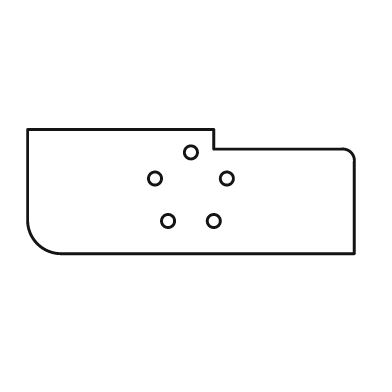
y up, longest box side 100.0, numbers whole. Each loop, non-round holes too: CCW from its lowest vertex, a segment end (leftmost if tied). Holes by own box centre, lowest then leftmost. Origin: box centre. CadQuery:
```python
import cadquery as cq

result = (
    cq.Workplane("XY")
    .moveTo(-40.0, -19.0)
    .lineTo(50.0, -19.0)
    .lineTo(50.0, 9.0)
    .threePointArc((49.0, 12.0), (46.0, 13.0))
    .lineTo(7.0, 13.0)
    .lineTo(7.0, 19.0)
    .lineTo(-50.0, 19.0)
    .lineTo(-50.0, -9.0)
    .threePointArc((-47.0, -16.0), (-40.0, -19.0))
    .close()
    .moveTo(-7.0, -9.0)
    .circle(2.0)
    .moveTo(7.0, -9.0)
    .circle(2.0)
    .moveTo(-11.0, 4.0)
    .circle(2.0)
    .moveTo(11.0, 4.0)
    .circle(2.0)
    .moveTo(0.0, 12.0)
    .circle(2.0)
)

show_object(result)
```